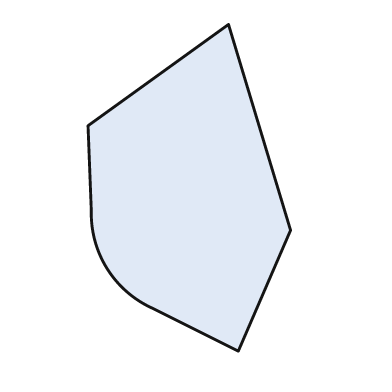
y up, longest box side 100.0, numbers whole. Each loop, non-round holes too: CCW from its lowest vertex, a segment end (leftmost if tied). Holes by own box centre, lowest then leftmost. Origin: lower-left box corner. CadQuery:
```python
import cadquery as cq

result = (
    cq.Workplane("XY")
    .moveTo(46.0, 0.0)
    .lineTo(62.0, 37.0)
    .lineTo(43.0, 100.0)
    .lineTo(0.0, 69.0)
    .lineTo(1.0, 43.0)
    .threePointArc((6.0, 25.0), (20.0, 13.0))
    .close()
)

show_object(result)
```